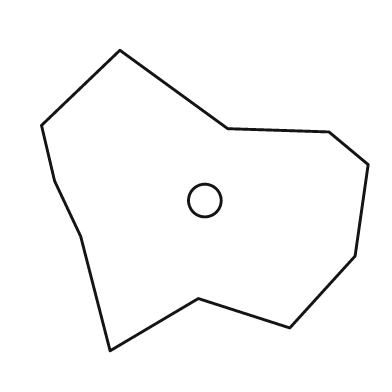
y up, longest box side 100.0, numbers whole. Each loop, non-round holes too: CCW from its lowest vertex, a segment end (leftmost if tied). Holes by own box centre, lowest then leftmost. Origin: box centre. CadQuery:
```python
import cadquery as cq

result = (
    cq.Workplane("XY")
    .moveTo(-29.0, -46.0)
    .lineTo(-2.0, -30.0)
    .lineTo(26.0, -39.0)
    .lineTo(46.0, -17.0)
    .lineTo(50.0, 11.0)
    .lineTo(38.0, 21.0)
    .lineTo(7.0, 22.0)
    .lineTo(-26.0, 46.0)
    .lineTo(-50.0, 23.0)
    .lineTo(-46.0, 6.0)
    .lineTo(-38.0, -11.0)
    .close()
    .moveTo(0.0, 0.0)
    .circle(5.0)
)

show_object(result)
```